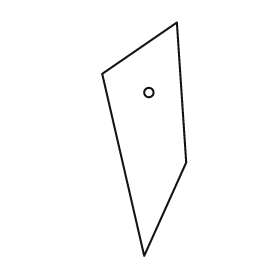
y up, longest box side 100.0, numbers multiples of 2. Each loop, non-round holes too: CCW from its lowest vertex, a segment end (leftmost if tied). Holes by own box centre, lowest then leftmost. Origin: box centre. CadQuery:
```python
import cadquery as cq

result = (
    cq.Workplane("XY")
    .moveTo(0.0, -50.0)
    .lineTo(18.0, -10.0)
    .lineTo(14.0, 50.0)
    .lineTo(-18.0, 28.0)
    .close()
    .moveTo(2.0, 20.0)
    .circle(2.0)
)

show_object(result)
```